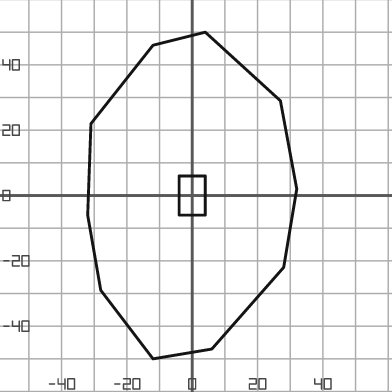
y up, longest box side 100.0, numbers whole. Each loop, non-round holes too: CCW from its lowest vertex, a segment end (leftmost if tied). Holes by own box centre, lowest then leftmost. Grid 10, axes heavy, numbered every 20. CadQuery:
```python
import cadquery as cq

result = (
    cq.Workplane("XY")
    .moveTo(-12.0, -50.0)
    .lineTo(6.0, -47.0)
    .lineTo(28.0, -22.0)
    .lineTo(32.0, 2.0)
    .lineTo(27.0, 29.0)
    .lineTo(4.0, 50.0)
    .lineTo(-12.0, 46.0)
    .lineTo(-31.0, 22.0)
    .lineTo(-32.0, -6.0)
    .lineTo(-28.0, -29.0)
    .close()
    .moveTo(-4.0, -6.0)
    .lineTo(4.0, -6.0)
    .lineTo(4.0, 6.0)
    .lineTo(-4.0, 6.0)
    .close()
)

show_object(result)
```